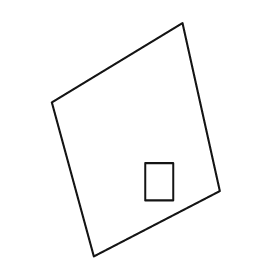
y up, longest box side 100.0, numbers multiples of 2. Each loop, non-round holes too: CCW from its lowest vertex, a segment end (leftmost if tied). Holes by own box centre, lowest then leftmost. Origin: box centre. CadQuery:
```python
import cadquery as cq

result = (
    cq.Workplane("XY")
    .moveTo(-18.0, -50.0)
    .lineTo(36.0, -22.0)
    .lineTo(20.0, 50.0)
    .lineTo(-36.0, 16.0)
    .close()
    .moveTo(4.0, -26.0)
    .lineTo(16.0, -26.0)
    .lineTo(16.0, -10.0)
    .lineTo(4.0, -10.0)
    .close()
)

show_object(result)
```